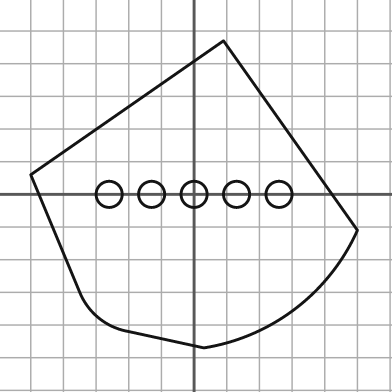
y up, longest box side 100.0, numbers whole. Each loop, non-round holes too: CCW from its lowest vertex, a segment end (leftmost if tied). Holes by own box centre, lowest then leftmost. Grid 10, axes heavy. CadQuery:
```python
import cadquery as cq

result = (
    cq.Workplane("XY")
    .moveTo(3.0, -47.0)
    .threePointArc((31.0, -35.0), (50.0, -11.0))
    .lineTo(9.0, 47.0)
    .lineTo(-50.0, 6.0)
    .lineTo(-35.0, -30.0)
    .threePointArc((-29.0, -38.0), (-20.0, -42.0))
    .close()
    .moveTo(-26.0, 0.0)
    .circle(4.0)
    .moveTo(-13.0, 0.0)
    .circle(4.0)
    .moveTo(0.0, 0.0)
    .circle(4.0)
    .moveTo(13.0, 0.0)
    .circle(4.0)
    .moveTo(26.0, 0.0)
    .circle(4.0)
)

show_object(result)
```